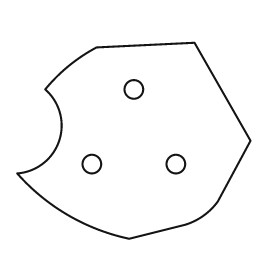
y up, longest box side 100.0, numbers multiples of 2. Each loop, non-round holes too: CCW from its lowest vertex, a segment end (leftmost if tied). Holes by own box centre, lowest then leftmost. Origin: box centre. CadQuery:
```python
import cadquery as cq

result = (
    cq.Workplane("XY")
    .moveTo(-2.0, -42.0)
    .lineTo(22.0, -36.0)
    .threePointArc((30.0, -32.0), (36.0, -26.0))
    .lineTo(50.0, 0.0)
    .lineTo(26.0, 42.0)
    .lineTo(-16.0, 40.0)
    .threePointArc((-28.0, 32.0), (-38.0, 22.0))
    .threePointArc((-32.0, 0.0), (-50.0, -14.0))
    .threePointArc((-28.0, -32.0), (-2.0, -42.0))
    .close()
    .moveTo(-18.0, -10.0)
    .circle(4.0)
    .moveTo(18.0, -10.0)
    .circle(4.0)
    .moveTo(0.0, 22.0)
    .circle(4.0)
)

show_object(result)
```